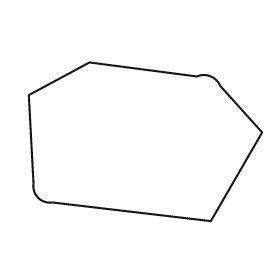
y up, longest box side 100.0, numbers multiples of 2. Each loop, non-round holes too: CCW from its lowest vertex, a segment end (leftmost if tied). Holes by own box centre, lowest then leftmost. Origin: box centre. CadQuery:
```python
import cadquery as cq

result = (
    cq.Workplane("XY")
    .moveTo(28.0, -34.0)
    .lineTo(50.0, 4.0)
    .lineTo(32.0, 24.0)
    .threePointArc((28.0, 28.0), (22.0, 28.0))
    .lineTo(-24.0, 34.0)
    .lineTo(-50.0, 20.0)
    .lineTo(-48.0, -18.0)
    .threePointArc((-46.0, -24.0), (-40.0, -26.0))
    .close()
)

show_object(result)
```